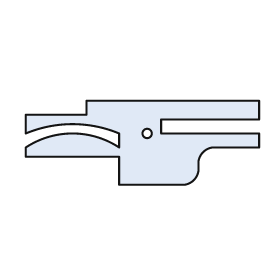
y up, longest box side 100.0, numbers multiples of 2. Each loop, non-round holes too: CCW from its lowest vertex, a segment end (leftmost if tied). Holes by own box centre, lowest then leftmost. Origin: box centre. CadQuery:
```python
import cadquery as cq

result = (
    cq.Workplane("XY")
    .moveTo(-10.0, -18.0)
    .lineTo(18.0, -18.0)
    .threePointArc((22.0, -16.0), (24.0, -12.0))
    .lineTo(24.0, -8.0)
    .threePointArc((26.0, -4.0), (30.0, -2.0))
    .lineTo(50.0, -2.0)
    .lineTo(50.0, 4.0)
    .lineTo(8.0, 4.0)
    .lineTo(8.0, 10.0)
    .lineTo(50.0, 10.0)
    .lineTo(50.0, 18.0)
    .lineTo(-24.0, 18.0)
    .lineTo(-24.0, 12.0)
    .lineTo(-50.0, 12.0)
    .lineTo(-50.0, 4.0)
    .threePointArc((-30.0, 8.0), (-10.0, 4.0))
    .lineTo(-10.0, -2.0)
    .threePointArc((-30.0, 4.0), (-50.0, -2.0))
    .lineTo(-50.0, -6.0)
    .lineTo(-10.0, -6.0)
    .close()
    .moveTo(2.0, 4.0)
    .circle(2.0)
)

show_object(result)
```